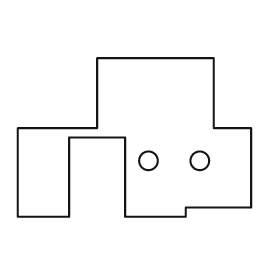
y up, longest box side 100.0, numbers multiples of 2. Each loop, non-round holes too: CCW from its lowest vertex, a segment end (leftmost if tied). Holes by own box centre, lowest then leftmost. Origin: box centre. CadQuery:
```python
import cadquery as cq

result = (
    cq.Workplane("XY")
    .moveTo(-50.0, -34.0)
    .lineTo(-28.0, -34.0)
    .lineTo(-28.0, 0.0)
    .lineTo(-4.0, 0.0)
    .lineTo(-4.0, -34.0)
    .lineTo(22.0, -34.0)
    .lineTo(22.0, -30.0)
    .lineTo(50.0, -30.0)
    .lineTo(50.0, 4.0)
    .lineTo(34.0, 4.0)
    .lineTo(34.0, 34.0)
    .lineTo(-16.0, 34.0)
    .lineTo(-16.0, 4.0)
    .lineTo(-50.0, 4.0)
    .close()
    .moveTo(6.0, -10.0)
    .circle(4.0)
    .moveTo(28.0, -10.0)
    .circle(4.0)
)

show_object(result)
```